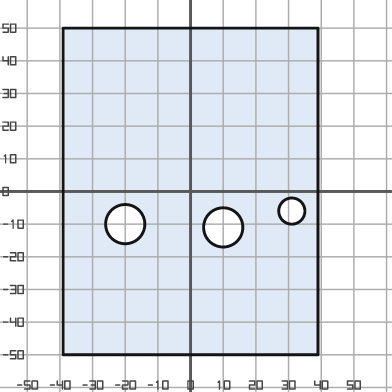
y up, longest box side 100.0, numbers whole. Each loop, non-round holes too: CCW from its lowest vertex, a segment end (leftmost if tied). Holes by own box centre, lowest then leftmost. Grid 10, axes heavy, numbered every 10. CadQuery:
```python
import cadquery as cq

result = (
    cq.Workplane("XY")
    .moveTo(-39.0, -50.0)
    .lineTo(39.0, -50.0)
    .lineTo(39.0, 50.0)
    .lineTo(-39.0, 50.0)
    .close()
    .moveTo(10.0, -11.0)
    .circle(6.0)
    .moveTo(-20.0, -10.0)
    .circle(6.0)
    .moveTo(31.0, -6.0)
    .circle(4.0)
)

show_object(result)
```